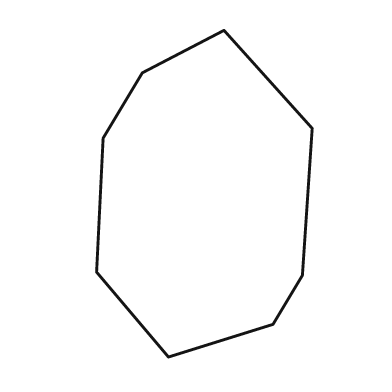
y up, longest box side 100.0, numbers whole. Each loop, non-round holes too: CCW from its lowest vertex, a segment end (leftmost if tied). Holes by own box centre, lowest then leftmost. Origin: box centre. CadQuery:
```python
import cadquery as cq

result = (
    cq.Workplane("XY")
    .moveTo(-11.0, -50.0)
    .lineTo(21.0, -40.0)
    .lineTo(30.0, -25.0)
    .lineTo(33.0, 20.0)
    .lineTo(6.0, 50.0)
    .lineTo(-19.0, 37.0)
    .lineTo(-31.0, 17.0)
    .lineTo(-33.0, -24.0)
    .close()
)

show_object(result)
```